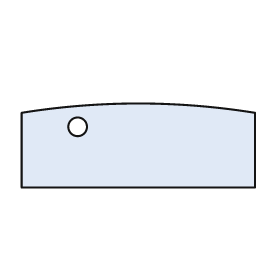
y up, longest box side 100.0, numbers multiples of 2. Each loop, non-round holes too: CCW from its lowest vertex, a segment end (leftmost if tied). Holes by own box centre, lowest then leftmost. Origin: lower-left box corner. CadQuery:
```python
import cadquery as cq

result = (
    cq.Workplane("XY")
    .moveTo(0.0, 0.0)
    .lineTo(100.0, 0.0)
    .lineTo(100.0, 32.0)
    .threePointArc((50.0, 36.0), (0.0, 32.0))
    .close()
    .moveTo(24.0, 26.0)
    .circle(4.0)
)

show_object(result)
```